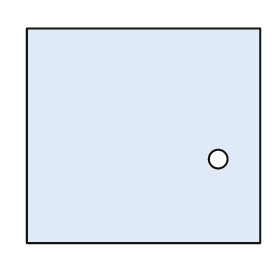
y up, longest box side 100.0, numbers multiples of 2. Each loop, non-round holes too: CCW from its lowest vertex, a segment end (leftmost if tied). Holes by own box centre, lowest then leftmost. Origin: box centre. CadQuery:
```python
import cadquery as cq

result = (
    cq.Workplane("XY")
    .moveTo(-50.0, -46.0)
    .lineTo(50.0, -46.0)
    .lineTo(50.0, 46.0)
    .lineTo(-50.0, 46.0)
    .close()
    .moveTo(32.0, -10.0)
    .circle(4.0)
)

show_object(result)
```